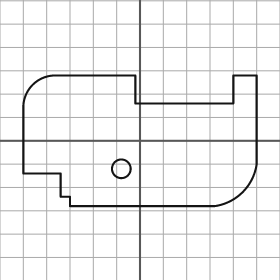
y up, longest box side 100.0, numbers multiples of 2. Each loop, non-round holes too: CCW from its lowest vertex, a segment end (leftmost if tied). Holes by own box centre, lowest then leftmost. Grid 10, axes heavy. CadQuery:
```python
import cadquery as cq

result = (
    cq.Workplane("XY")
    .moveTo(-30.0, -28.0)
    .lineTo(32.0, -28.0)
    .threePointArc((44.0, -22.0), (50.0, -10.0))
    .lineTo(50.0, 28.0)
    .lineTo(40.0, 28.0)
    .lineTo(40.0, 16.0)
    .lineTo(-2.0, 16.0)
    .lineTo(-2.0, 28.0)
    .lineTo(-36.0, 28.0)
    .threePointArc((-46.0, 24.0), (-50.0, 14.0))
    .lineTo(-50.0, -14.0)
    .lineTo(-34.0, -14.0)
    .lineTo(-34.0, -24.0)
    .lineTo(-30.0, -24.0)
    .close()
    .moveTo(-8.0, -12.0)
    .circle(4.0)
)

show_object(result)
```